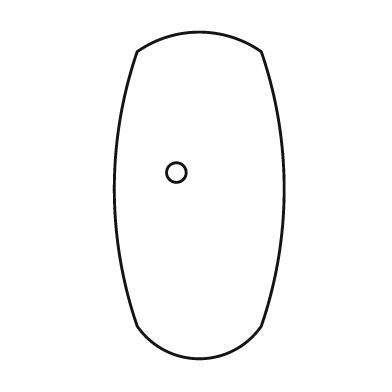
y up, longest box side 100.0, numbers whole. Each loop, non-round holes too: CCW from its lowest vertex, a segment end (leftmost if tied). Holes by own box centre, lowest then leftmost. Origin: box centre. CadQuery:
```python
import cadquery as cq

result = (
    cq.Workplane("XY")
    .moveTo(-19.0, -40.0)
    .threePointArc((0.0, -50.0), (19.0, -40.0))
    .threePointArc((26.0, 2.0), (19.0, 44.0))
    .threePointArc((0.0, 50.0), (-19.0, 44.0))
    .threePointArc((-26.0, 2.0), (-19.0, -40.0))
    .close()
    .moveTo(-7.0, 7.0)
    .circle(3.0)
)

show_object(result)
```